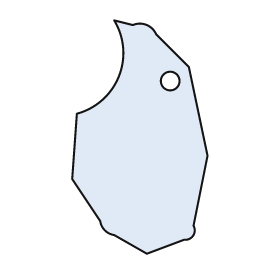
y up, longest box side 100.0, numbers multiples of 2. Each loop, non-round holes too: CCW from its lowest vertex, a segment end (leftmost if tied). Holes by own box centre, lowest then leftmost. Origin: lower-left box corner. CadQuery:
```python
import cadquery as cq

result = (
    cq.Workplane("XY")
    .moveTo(32.0, 0.0)
    .lineTo(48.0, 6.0)
    .threePointArc((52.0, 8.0), (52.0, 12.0))
    .lineTo(58.0, 42.0)
    .lineTo(50.0, 80.0)
    .lineTo(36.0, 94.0)
    .threePointArc((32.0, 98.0), (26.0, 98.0))
    .lineTo(18.0, 100.0)
    .threePointArc((20.0, 76.0), (2.0, 60.0))
    .lineTo(0.0, 32.0)
    .lineTo(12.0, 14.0)
    .threePointArc((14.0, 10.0), (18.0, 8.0))
    .close()
    .moveTo(42.0, 74.0)
    .circle(4.0)
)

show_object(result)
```